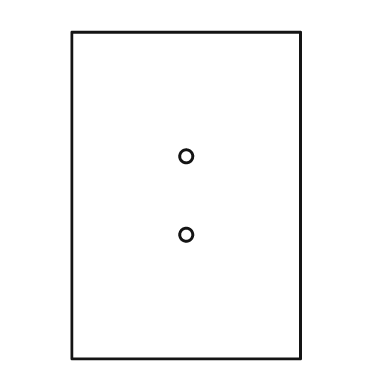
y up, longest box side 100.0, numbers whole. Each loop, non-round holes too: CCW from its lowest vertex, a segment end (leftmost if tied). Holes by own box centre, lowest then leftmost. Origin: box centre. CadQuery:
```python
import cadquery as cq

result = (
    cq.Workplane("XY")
    .moveTo(-35.0, -50.0)
    .lineTo(35.0, -50.0)
    .lineTo(35.0, 50.0)
    .lineTo(-35.0, 50.0)
    .close()
    .moveTo(0.0, -12.0)
    .circle(2.0)
    .moveTo(0.0, 12.0)
    .circle(2.0)
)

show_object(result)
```